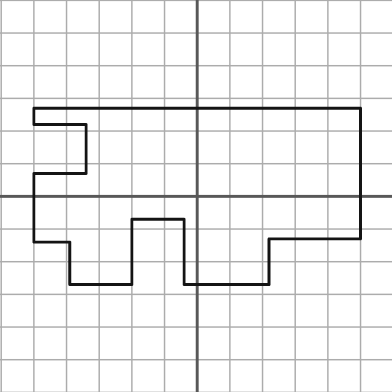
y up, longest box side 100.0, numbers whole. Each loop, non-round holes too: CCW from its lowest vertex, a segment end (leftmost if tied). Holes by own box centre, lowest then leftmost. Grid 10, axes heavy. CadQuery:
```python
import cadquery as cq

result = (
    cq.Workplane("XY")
    .moveTo(-39.0, -27.0)
    .lineTo(-20.0, -27.0)
    .lineTo(-20.0, -7.0)
    .lineTo(-4.0, -7.0)
    .lineTo(-4.0, -27.0)
    .lineTo(22.0, -27.0)
    .lineTo(22.0, -13.0)
    .lineTo(50.0, -13.0)
    .lineTo(50.0, 27.0)
    .lineTo(-50.0, 27.0)
    .lineTo(-50.0, 22.0)
    .lineTo(-34.0, 22.0)
    .lineTo(-34.0, 7.0)
    .lineTo(-50.0, 7.0)
    .lineTo(-50.0, -14.0)
    .lineTo(-39.0, -14.0)
    .close()
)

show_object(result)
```